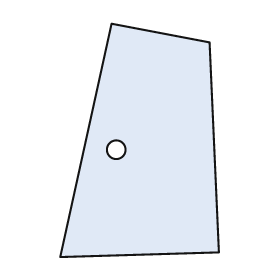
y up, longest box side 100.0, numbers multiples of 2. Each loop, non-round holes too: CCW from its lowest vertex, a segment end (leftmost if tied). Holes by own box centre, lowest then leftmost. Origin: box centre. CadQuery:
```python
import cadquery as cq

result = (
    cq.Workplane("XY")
    .moveTo(-34.0, -50.0)
    .lineTo(34.0, -48.0)
    .lineTo(30.0, 42.0)
    .lineTo(-12.0, 50.0)
    .close()
    .moveTo(-10.0, -4.0)
    .circle(4.0)
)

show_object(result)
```